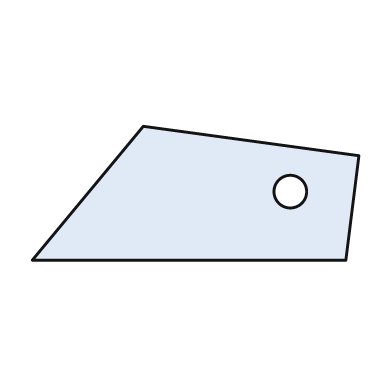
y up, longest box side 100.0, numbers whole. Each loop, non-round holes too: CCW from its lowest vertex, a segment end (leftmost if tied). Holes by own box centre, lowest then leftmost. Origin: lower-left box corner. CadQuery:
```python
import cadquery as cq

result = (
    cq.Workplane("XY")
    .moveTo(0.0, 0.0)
    .lineTo(96.0, 0.0)
    .lineTo(100.0, 32.0)
    .lineTo(34.0, 41.0)
    .close()
    .moveTo(79.0, 21.0)
    .circle(5.0)
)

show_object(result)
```